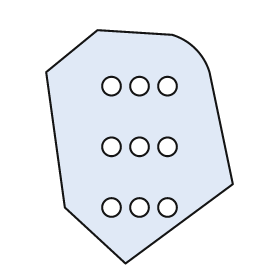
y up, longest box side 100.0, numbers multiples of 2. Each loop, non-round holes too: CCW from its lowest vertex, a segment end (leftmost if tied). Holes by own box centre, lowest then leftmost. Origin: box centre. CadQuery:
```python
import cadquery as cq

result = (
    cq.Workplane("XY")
    .moveTo(-6.0, -50.0)
    .lineTo(40.0, -16.0)
    .lineTo(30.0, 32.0)
    .threePointArc((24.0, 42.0), (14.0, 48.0))
    .lineTo(-18.0, 50.0)
    .lineTo(-40.0, 32.0)
    .lineTo(-32.0, -26.0)
    .close()
    .moveTo(-12.0, -26.0)
    .circle(4.0)
    .moveTo(0.0, -26.0)
    .circle(4.0)
    .moveTo(12.0, -26.0)
    .circle(4.0)
    .moveTo(-12.0, 0.0)
    .circle(4.0)
    .moveTo(0.0, 0.0)
    .circle(4.0)
    .moveTo(12.0, 0.0)
    .circle(4.0)
    .moveTo(-12.0, 26.0)
    .circle(4.0)
    .moveTo(0.0, 26.0)
    .circle(4.0)
    .moveTo(12.0, 26.0)
    .circle(4.0)
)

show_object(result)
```